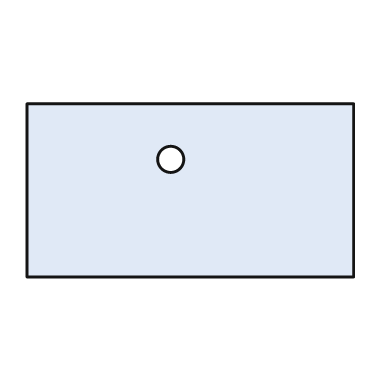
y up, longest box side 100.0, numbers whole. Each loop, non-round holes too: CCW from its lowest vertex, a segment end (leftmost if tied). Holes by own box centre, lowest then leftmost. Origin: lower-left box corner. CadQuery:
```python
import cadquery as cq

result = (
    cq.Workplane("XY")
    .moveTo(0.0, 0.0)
    .lineTo(100.0, 0.0)
    .lineTo(100.0, 53.0)
    .lineTo(0.0, 53.0)
    .close()
    .moveTo(44.0, 36.0)
    .circle(4.0)
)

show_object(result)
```